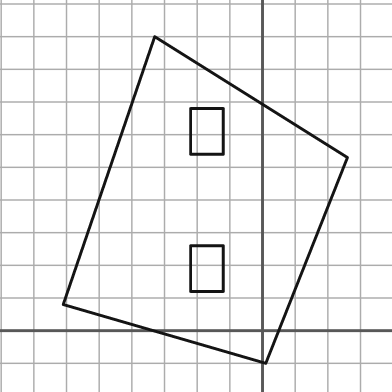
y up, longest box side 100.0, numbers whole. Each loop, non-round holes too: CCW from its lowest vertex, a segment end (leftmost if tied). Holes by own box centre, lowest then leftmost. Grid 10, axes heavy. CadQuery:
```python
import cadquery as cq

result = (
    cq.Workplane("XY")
    .moveTo(1.0, -10.0)
    .lineTo(26.0, 53.0)
    .lineTo(-33.0, 90.0)
    .lineTo(-61.0, 8.0)
    .close()
    .moveTo(-22.0, 12.0)
    .lineTo(-12.0, 12.0)
    .lineTo(-12.0, 26.0)
    .lineTo(-22.0, 26.0)
    .close()
    .moveTo(-22.0, 54.0)
    .lineTo(-12.0, 54.0)
    .lineTo(-12.0, 68.0)
    .lineTo(-22.0, 68.0)
    .close()
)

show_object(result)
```